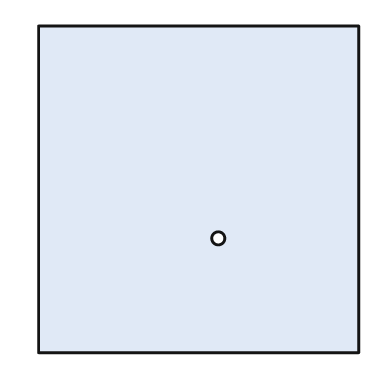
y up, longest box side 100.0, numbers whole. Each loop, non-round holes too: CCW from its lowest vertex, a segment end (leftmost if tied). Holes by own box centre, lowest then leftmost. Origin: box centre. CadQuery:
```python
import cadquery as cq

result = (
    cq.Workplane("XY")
    .moveTo(-49.0, -50.0)
    .lineTo(49.0, -50.0)
    .lineTo(49.0, 50.0)
    .lineTo(-49.0, 50.0)
    .close()
    .moveTo(6.0, -15.0)
    .circle(2.0)
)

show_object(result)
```